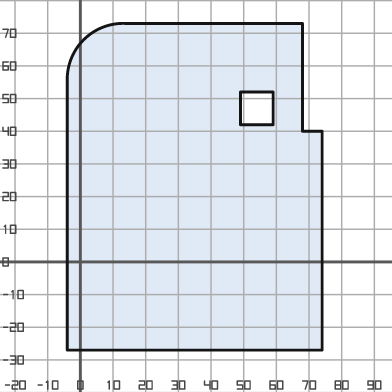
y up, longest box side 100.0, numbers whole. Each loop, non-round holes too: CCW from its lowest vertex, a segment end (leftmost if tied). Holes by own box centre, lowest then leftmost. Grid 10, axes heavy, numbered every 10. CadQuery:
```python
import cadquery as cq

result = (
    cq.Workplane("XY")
    .moveTo(-4.0, -27.0)
    .lineTo(74.0, -27.0)
    .lineTo(74.0, 40.0)
    .lineTo(68.0, 40.0)
    .lineTo(68.0, 73.0)
    .lineTo(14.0, 73.0)
    .threePointArc((1.0, 68.0), (-4.0, 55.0))
    .close()
    .moveTo(49.0, 42.0)
    .lineTo(59.0, 42.0)
    .lineTo(59.0, 52.0)
    .lineTo(49.0, 52.0)
    .close()
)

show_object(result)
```